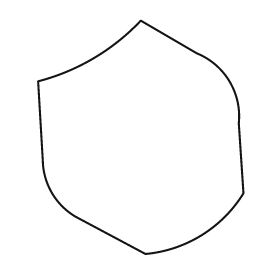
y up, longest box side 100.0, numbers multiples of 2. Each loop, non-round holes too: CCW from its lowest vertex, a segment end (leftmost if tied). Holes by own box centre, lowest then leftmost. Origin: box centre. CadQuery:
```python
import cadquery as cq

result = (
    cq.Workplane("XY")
    .moveTo(2.0, -50.0)
    .threePointArc((26.0, -42.0), (44.0, -24.0))
    .lineTo(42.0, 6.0)
    .threePointArc((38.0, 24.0), (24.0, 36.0))
    .lineTo(0.0, 50.0)
    .threePointArc((-20.0, 34.0), (-44.0, 24.0))
    .lineTo(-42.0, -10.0)
    .threePointArc((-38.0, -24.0), (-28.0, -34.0))
    .close()
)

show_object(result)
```